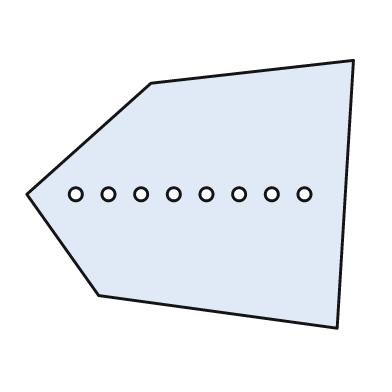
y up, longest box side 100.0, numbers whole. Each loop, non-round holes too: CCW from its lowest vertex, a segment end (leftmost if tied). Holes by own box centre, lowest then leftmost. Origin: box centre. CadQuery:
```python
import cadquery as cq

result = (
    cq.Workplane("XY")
    .moveTo(45.0, -41.0)
    .lineTo(50.0, 41.0)
    .lineTo(-12.0, 34.0)
    .lineTo(-50.0, 0.0)
    .lineTo(-28.0, -31.0)
    .close()
    .moveTo(-35.0, 0.0)
    .circle(2.0)
    .moveTo(-25.0, 0.0)
    .circle(2.0)
    .moveTo(-15.0, 0.0)
    .circle(2.0)
    .moveTo(-5.0, 0.0)
    .circle(2.0)
    .moveTo(5.0, 0.0)
    .circle(2.0)
    .moveTo(15.0, 0.0)
    .circle(2.0)
    .moveTo(25.0, 0.0)
    .circle(2.0)
    .moveTo(35.0, 0.0)
    .circle(2.0)
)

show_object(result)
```